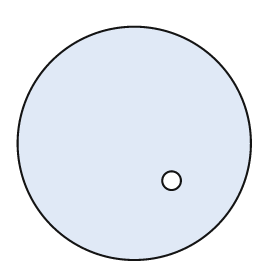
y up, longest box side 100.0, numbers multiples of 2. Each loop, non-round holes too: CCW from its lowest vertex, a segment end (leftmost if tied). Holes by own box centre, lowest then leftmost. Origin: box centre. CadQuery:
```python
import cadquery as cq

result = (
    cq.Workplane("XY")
    .moveTo(0.0, 0.0)
    .circle(50.0)
    .moveTo(16.0, -16.0)
    .circle(4.0)
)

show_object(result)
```